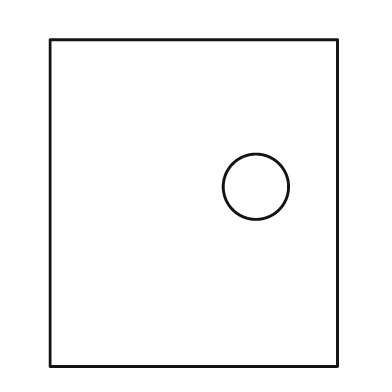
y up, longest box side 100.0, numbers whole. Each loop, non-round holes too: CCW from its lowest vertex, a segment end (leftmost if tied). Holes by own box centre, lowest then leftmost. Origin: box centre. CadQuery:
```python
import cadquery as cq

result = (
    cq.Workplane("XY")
    .moveTo(-44.0, -50.0)
    .lineTo(44.0, -50.0)
    .lineTo(44.0, 50.0)
    .lineTo(-44.0, 50.0)
    .close()
    .moveTo(19.0, 5.0)
    .circle(10.0)
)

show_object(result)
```